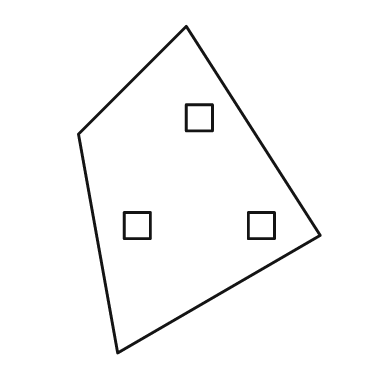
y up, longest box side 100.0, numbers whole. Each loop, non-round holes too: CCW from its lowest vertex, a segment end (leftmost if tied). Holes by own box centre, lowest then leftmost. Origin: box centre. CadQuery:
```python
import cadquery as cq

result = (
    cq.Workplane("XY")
    .moveTo(-25.0, -50.0)
    .lineTo(37.0, -14.0)
    .lineTo(-4.0, 50.0)
    .lineTo(-37.0, 17.0)
    .close()
    .moveTo(-23.0, -15.0)
    .lineTo(-15.0, -15.0)
    .lineTo(-15.0, -7.0)
    .lineTo(-23.0, -7.0)
    .close()
    .moveTo(15.0, -15.0)
    .lineTo(23.0, -15.0)
    .lineTo(23.0, -7.0)
    .lineTo(15.0, -7.0)
    .close()
    .moveTo(-4.0, 18.0)
    .lineTo(4.0, 18.0)
    .lineTo(4.0, 26.0)
    .lineTo(-4.0, 26.0)
    .close()
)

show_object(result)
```